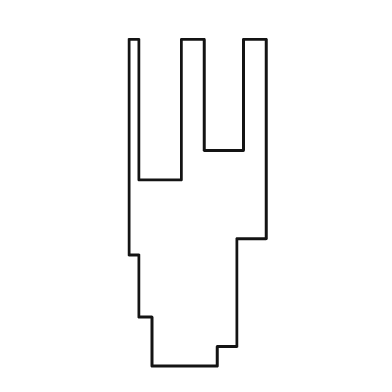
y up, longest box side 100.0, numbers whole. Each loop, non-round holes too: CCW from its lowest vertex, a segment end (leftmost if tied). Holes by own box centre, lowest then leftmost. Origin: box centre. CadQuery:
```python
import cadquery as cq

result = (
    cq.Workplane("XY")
    .moveTo(-14.0, -50.0)
    .lineTo(6.0, -50.0)
    .lineTo(6.0, -44.0)
    .lineTo(12.0, -44.0)
    .lineTo(12.0, -11.0)
    .lineTo(21.0, -11.0)
    .lineTo(21.0, 50.0)
    .lineTo(14.0, 50.0)
    .lineTo(14.0, 16.0)
    .lineTo(2.0, 16.0)
    .lineTo(2.0, 50.0)
    .lineTo(-5.0, 50.0)
    .lineTo(-5.0, 7.0)
    .lineTo(-18.0, 7.0)
    .lineTo(-18.0, 50.0)
    .lineTo(-21.0, 50.0)
    .lineTo(-21.0, -16.0)
    .lineTo(-18.0, -16.0)
    .lineTo(-18.0, -35.0)
    .lineTo(-14.0, -35.0)
    .close()
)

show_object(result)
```